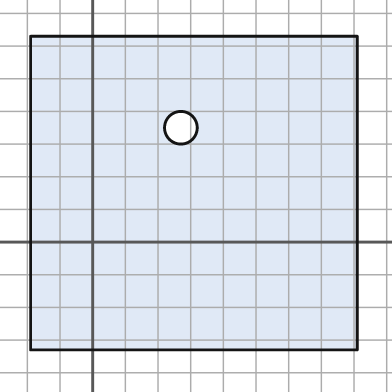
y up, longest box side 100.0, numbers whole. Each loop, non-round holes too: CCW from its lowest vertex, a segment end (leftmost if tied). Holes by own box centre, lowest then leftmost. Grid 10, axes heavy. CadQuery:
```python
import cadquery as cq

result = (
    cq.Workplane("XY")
    .moveTo(-19.0, -33.0)
    .lineTo(81.0, -33.0)
    .lineTo(81.0, 63.0)
    .lineTo(-19.0, 63.0)
    .close()
    .moveTo(27.0, 35.0)
    .circle(5.0)
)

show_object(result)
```